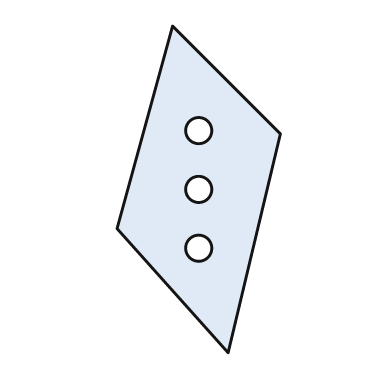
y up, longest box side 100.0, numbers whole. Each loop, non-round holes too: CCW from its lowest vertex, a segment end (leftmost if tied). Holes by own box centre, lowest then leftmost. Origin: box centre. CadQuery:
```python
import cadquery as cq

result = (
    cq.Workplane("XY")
    .moveTo(9.0, -50.0)
    .lineTo(25.0, 17.0)
    .lineTo(-8.0, 50.0)
    .lineTo(-25.0, -12.0)
    .close()
    .moveTo(0.0, -18.0)
    .circle(4.0)
    .moveTo(0.0, 0.0)
    .circle(4.0)
    .moveTo(0.0, 18.0)
    .circle(4.0)
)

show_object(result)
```